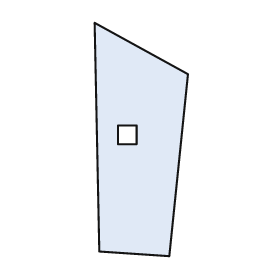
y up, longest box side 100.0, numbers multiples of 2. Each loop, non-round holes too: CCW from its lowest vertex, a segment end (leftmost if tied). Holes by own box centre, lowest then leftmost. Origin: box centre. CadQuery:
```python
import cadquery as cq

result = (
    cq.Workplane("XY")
    .moveTo(12.0, -50.0)
    .lineTo(20.0, 28.0)
    .lineTo(-20.0, 50.0)
    .lineTo(-18.0, -48.0)
    .close()
    .moveTo(-10.0, -2.0)
    .lineTo(-2.0, -2.0)
    .lineTo(-2.0, 6.0)
    .lineTo(-10.0, 6.0)
    .close()
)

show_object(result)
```